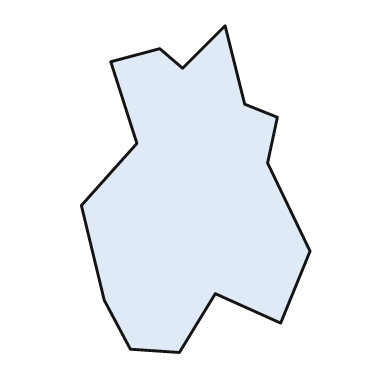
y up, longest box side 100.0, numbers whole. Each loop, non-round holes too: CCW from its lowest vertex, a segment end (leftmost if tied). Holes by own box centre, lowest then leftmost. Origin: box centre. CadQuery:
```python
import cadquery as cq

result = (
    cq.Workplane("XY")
    .moveTo(-5.0, -50.0)
    .lineTo(6.0, -32.0)
    .lineTo(26.0, -41.0)
    .lineTo(35.0, -19.0)
    .lineTo(22.0, 8.0)
    .lineTo(25.0, 22.0)
    .lineTo(15.0, 26.0)
    .lineTo(9.0, 50.0)
    .lineTo(-4.0, 37.0)
    .lineTo(-11.0, 43.0)
    .lineTo(-26.0, 39.0)
    .lineTo(-18.0, 14.0)
    .lineTo(-35.0, -5.0)
    .lineTo(-28.0, -34.0)
    .lineTo(-20.0, -49.0)
    .close()
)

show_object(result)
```